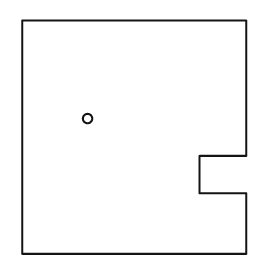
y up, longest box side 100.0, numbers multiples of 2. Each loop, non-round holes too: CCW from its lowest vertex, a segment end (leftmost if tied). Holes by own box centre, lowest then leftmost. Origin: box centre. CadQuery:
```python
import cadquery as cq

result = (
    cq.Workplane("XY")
    .moveTo(-48.0, -50.0)
    .lineTo(48.0, -50.0)
    .lineTo(48.0, -24.0)
    .lineTo(28.0, -24.0)
    .lineTo(28.0, -8.0)
    .lineTo(48.0, -8.0)
    .lineTo(48.0, 50.0)
    .lineTo(-48.0, 50.0)
    .close()
    .moveTo(-20.0, 8.0)
    .circle(2.0)
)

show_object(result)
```